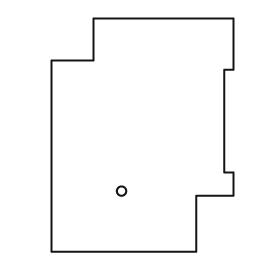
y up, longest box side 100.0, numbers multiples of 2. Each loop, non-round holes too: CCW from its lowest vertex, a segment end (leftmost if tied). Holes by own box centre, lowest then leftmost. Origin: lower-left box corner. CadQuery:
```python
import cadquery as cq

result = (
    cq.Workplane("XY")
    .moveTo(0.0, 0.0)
    .lineTo(62.0, 0.0)
    .lineTo(62.0, 24.0)
    .lineTo(78.0, 24.0)
    .lineTo(78.0, 34.0)
    .lineTo(74.0, 34.0)
    .lineTo(74.0, 78.0)
    .lineTo(78.0, 78.0)
    .lineTo(78.0, 100.0)
    .lineTo(18.0, 100.0)
    .lineTo(18.0, 82.0)
    .lineTo(0.0, 82.0)
    .close()
    .moveTo(30.0, 26.0)
    .circle(2.0)
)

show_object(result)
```